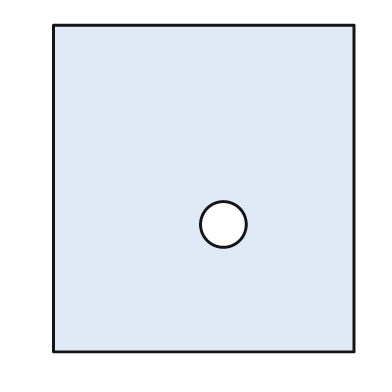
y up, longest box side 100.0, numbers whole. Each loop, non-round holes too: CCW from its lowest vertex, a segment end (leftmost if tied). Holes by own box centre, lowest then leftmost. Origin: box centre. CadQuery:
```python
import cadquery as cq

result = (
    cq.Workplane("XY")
    .moveTo(-46.0, -50.0)
    .lineTo(46.0, -50.0)
    .lineTo(46.0, 50.0)
    .lineTo(-46.0, 50.0)
    .close()
    .moveTo(6.0, -11.0)
    .circle(7.0)
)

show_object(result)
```